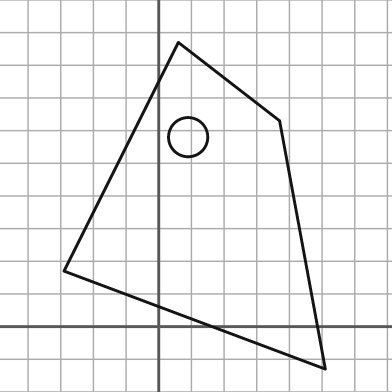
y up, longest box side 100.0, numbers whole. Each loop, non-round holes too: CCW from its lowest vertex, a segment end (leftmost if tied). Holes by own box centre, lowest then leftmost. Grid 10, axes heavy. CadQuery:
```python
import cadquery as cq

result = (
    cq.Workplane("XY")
    .moveTo(51.0, -13.0)
    .lineTo(37.0, 63.0)
    .lineTo(6.0, 87.0)
    .lineTo(-29.0, 17.0)
    .close()
    .moveTo(9.0, 58.0)
    .circle(6.0)
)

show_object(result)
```